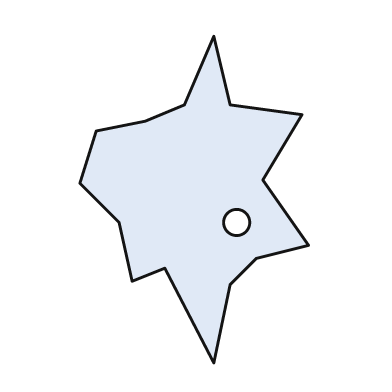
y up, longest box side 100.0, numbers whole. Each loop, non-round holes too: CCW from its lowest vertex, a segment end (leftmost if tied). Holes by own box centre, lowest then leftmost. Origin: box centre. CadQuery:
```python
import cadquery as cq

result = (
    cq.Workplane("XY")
    .moveTo(6.0, -50.0)
    .lineTo(11.0, -26.0)
    .lineTo(19.0, -18.0)
    .lineTo(35.0, -14.0)
    .lineTo(21.0, 6.0)
    .lineTo(33.0, 26.0)
    .lineTo(11.0, 29.0)
    .lineTo(6.0, 50.0)
    .lineTo(-3.0, 29.0)
    .lineTo(-15.0, 24.0)
    .lineTo(-30.0, 21.0)
    .lineTo(-35.0, 5.0)
    .lineTo(-23.0, -7.0)
    .lineTo(-19.0, -25.0)
    .lineTo(-9.0, -21.0)
    .close()
    .moveTo(13.0, -7.0)
    .circle(4.0)
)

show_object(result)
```